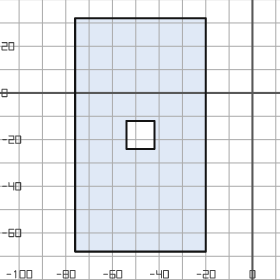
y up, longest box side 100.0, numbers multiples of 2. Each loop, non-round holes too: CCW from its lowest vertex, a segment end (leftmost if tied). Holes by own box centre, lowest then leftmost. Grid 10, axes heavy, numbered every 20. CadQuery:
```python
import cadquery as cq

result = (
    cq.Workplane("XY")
    .moveTo(-76.0, -68.0)
    .lineTo(-20.0, -68.0)
    .lineTo(-20.0, 32.0)
    .lineTo(-76.0, 32.0)
    .close()
    .moveTo(-54.0, -24.0)
    .lineTo(-42.0, -24.0)
    .lineTo(-42.0, -12.0)
    .lineTo(-54.0, -12.0)
    .close()
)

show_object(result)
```